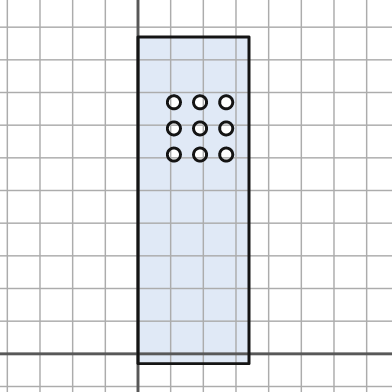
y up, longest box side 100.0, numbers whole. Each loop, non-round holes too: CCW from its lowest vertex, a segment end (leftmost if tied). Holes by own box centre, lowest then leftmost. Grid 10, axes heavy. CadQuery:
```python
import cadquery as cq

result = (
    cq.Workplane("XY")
    .moveTo(0.0, -3.0)
    .lineTo(34.0, -3.0)
    .lineTo(34.0, 97.0)
    .lineTo(0.0, 97.0)
    .close()
    .moveTo(11.0, 61.0)
    .circle(2.0)
    .moveTo(19.0, 61.0)
    .circle(2.0)
    .moveTo(27.0, 61.0)
    .circle(2.0)
    .moveTo(11.0, 69.0)
    .circle(2.0)
    .moveTo(19.0, 69.0)
    .circle(2.0)
    .moveTo(27.0, 69.0)
    .circle(2.0)
    .moveTo(11.0, 77.0)
    .circle(2.0)
    .moveTo(19.0, 77.0)
    .circle(2.0)
    .moveTo(27.0, 77.0)
    .circle(2.0)
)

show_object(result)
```